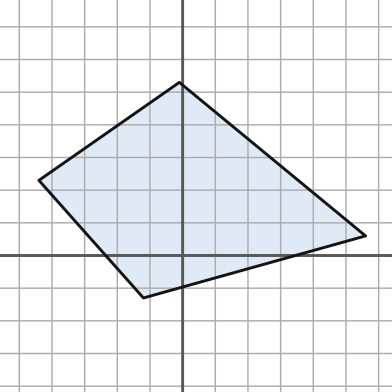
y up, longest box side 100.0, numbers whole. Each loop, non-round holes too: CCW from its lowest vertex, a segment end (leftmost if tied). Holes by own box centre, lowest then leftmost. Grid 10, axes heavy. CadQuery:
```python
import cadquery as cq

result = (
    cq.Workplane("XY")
    .moveTo(-12.0, -13.0)
    .lineTo(56.0, 6.0)
    .lineTo(-1.0, 53.0)
    .lineTo(-44.0, 23.0)
    .close()
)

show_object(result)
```